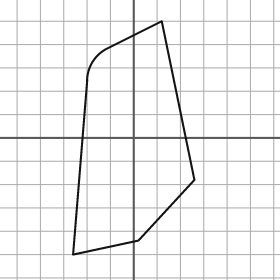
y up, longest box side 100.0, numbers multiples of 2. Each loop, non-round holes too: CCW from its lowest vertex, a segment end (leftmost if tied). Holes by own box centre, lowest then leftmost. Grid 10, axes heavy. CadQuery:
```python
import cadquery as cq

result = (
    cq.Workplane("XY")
    .moveTo(-26.0, -50.0)
    .lineTo(2.0, -44.0)
    .lineTo(26.0, -18.0)
    .lineTo(12.0, 50.0)
    .lineTo(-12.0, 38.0)
    .threePointArc((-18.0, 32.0), (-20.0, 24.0))
    .close()
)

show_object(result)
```